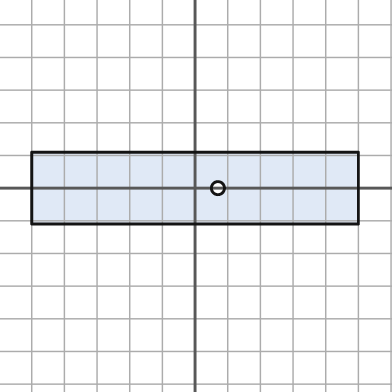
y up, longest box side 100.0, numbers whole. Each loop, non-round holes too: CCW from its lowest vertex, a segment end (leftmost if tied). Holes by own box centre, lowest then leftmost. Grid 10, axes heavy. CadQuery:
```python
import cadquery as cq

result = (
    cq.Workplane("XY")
    .moveTo(-50.0, -11.0)
    .lineTo(50.0, -11.0)
    .lineTo(50.0, 11.0)
    .lineTo(-50.0, 11.0)
    .close()
    .moveTo(7.0, 0.0)
    .circle(2.0)
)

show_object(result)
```